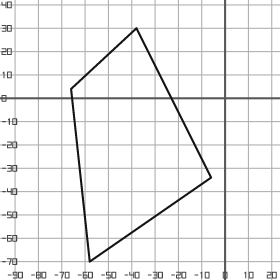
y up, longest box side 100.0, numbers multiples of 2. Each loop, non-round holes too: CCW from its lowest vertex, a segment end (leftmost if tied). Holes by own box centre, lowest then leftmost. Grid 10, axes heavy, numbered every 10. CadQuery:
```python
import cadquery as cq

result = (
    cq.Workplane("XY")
    .moveTo(-58.0, -70.0)
    .lineTo(-6.0, -34.0)
    .lineTo(-38.0, 30.0)
    .lineTo(-66.0, 4.0)
    .close()
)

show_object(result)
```